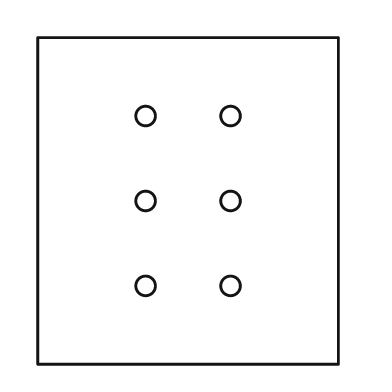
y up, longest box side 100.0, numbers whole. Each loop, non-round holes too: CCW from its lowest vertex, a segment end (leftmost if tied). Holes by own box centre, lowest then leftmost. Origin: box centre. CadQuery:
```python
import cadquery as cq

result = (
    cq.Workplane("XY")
    .moveTo(-46.0, -50.0)
    .lineTo(46.0, -50.0)
    .lineTo(46.0, 50.0)
    .lineTo(-46.0, 50.0)
    .close()
    .moveTo(-13.0, -26.0)
    .circle(3.0)
    .moveTo(13.0, -26.0)
    .circle(3.0)
    .moveTo(-13.0, 0.0)
    .circle(3.0)
    .moveTo(13.0, 0.0)
    .circle(3.0)
    .moveTo(-13.0, 26.0)
    .circle(3.0)
    .moveTo(13.0, 26.0)
    .circle(3.0)
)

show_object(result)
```